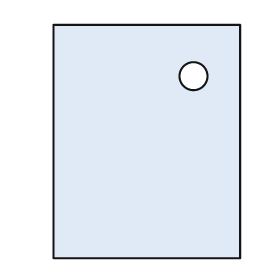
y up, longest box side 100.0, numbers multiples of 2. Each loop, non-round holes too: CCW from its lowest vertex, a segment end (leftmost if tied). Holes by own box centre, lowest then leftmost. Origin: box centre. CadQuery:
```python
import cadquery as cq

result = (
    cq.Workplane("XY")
    .moveTo(-40.0, -50.0)
    .lineTo(40.0, -50.0)
    .lineTo(40.0, 50.0)
    .lineTo(-40.0, 50.0)
    .close()
    .moveTo(20.0, 28.0)
    .circle(6.0)
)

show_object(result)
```